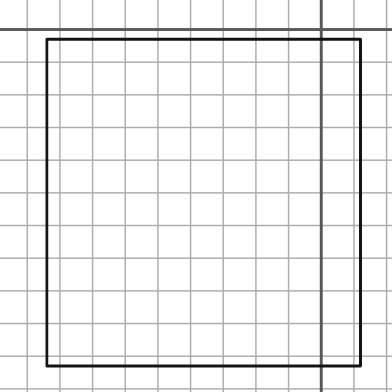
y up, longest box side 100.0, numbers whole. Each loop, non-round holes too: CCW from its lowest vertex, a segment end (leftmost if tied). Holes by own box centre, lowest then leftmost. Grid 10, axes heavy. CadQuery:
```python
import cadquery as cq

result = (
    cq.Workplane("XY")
    .moveTo(-84.0, -103.0)
    .lineTo(12.0, -103.0)
    .lineTo(12.0, -3.0)
    .lineTo(-84.0, -3.0)
    .close()
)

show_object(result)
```